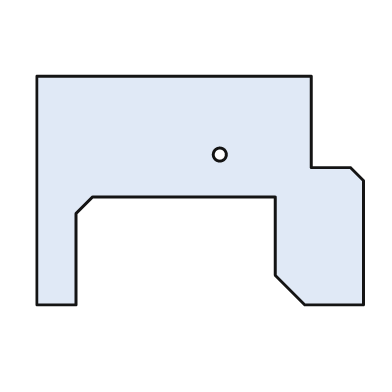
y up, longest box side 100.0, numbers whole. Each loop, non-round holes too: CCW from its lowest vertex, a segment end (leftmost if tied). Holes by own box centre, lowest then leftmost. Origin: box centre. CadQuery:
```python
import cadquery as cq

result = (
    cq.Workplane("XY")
    .moveTo(-50.0, -35.0)
    .lineTo(-38.0, -35.0)
    .lineTo(-38.0, -7.0)
    .lineTo(-33.0, -2.0)
    .lineTo(23.0, -2.0)
    .lineTo(23.0, -26.0)
    .lineTo(32.0, -35.0)
    .lineTo(50.0, -35.0)
    .lineTo(50.0, 3.0)
    .lineTo(46.0, 7.0)
    .lineTo(34.0, 7.0)
    .lineTo(34.0, 35.0)
    .lineTo(-50.0, 35.0)
    .close()
    .moveTo(6.0, 11.0)
    .circle(2.0)
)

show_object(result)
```